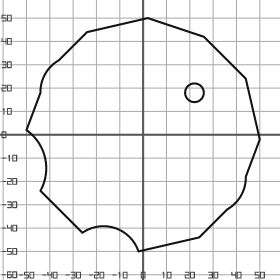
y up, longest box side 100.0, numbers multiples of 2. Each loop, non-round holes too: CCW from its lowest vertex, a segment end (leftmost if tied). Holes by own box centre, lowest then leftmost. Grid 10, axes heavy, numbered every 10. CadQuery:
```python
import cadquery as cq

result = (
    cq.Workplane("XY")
    .moveTo(-2.0, -50.0)
    .lineTo(24.0, -44.0)
    .lineTo(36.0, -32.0)
    .threePointArc((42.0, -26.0), (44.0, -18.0))
    .lineTo(50.0, -2.0)
    .lineTo(44.0, 24.0)
    .lineTo(26.0, 42.0)
    .lineTo(2.0, 50.0)
    .lineTo(-24.0, 44.0)
    .lineTo(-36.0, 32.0)
    .threePointArc((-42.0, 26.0), (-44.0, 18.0))
    .lineTo(-50.0, 2.0)
    .threePointArc((-42.0, -10.0), (-44.0, -24.0))
    .lineTo(-26.0, -42.0)
    .threePointArc((-12.0, -40.0), (-2.0, -50.0))
    .close()
    .moveTo(22.0, 18.0)
    .circle(4.0)
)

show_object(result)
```